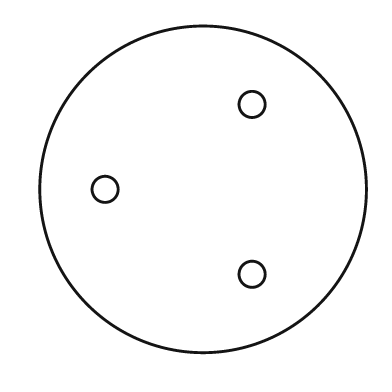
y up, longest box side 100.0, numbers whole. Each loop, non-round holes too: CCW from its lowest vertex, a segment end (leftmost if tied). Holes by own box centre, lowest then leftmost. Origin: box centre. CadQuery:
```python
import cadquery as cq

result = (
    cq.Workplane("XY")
    .moveTo(0.0, 0.0)
    .circle(50.0)
    .moveTo(15.0, -26.0)
    .circle(4.0)
    .moveTo(-30.0, 0.0)
    .circle(4.0)
    .moveTo(15.0, 26.0)
    .circle(4.0)
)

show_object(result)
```